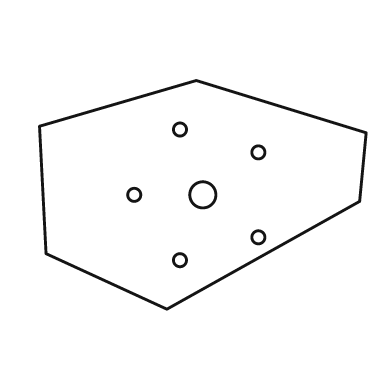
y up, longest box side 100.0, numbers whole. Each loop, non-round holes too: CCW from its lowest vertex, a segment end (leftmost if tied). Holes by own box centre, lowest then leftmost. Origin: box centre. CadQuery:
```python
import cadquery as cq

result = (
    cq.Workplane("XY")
    .moveTo(-11.0, -35.0)
    .lineTo(48.0, -2.0)
    .lineTo(50.0, 19.0)
    .lineTo(-2.0, 35.0)
    .lineTo(-50.0, 21.0)
    .lineTo(-48.0, -18.0)
    .close()
    .moveTo(-7.0, -20.0)
    .circle(2.0)
    .moveTo(17.0, -13.0)
    .circle(2.0)
    .moveTo(-21.0, 0.0)
    .circle(2.0)
    .moveTo(0.0, 0.0)
    .circle(4.0)
    .moveTo(17.0, 13.0)
    .circle(2.0)
    .moveTo(-7.0, 20.0)
    .circle(2.0)
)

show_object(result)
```